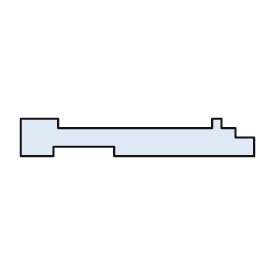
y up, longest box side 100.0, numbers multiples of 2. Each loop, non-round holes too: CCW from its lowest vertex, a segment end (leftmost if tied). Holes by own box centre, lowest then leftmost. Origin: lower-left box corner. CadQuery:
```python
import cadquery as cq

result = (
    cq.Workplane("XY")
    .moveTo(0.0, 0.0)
    .lineTo(14.0, 0.0)
    .lineTo(14.0, 4.0)
    .lineTo(40.0, 4.0)
    .lineTo(40.0, 0.0)
    .lineTo(100.0, 0.0)
    .lineTo(100.0, 8.0)
    .lineTo(92.0, 8.0)
    .lineTo(92.0, 12.0)
    .lineTo(86.0, 12.0)
    .lineTo(86.0, 16.0)
    .lineTo(82.0, 16.0)
    .lineTo(82.0, 12.0)
    .lineTo(16.0, 12.0)
    .lineTo(16.0, 16.0)
    .lineTo(0.0, 16.0)
    .close()
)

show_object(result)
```